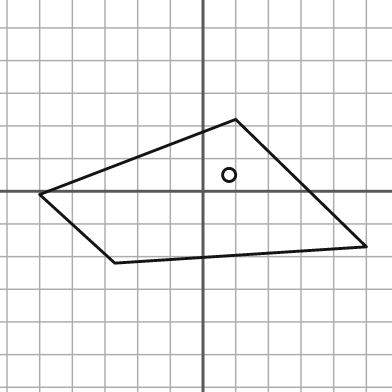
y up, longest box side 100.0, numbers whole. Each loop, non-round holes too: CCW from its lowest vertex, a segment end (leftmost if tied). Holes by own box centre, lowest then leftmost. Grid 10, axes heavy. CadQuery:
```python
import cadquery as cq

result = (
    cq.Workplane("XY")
    .moveTo(-27.0, -22.0)
    .lineTo(50.0, -17.0)
    .lineTo(10.0, 22.0)
    .lineTo(-50.0, -1.0)
    .close()
    .moveTo(8.0, 5.0)
    .circle(2.0)
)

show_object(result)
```